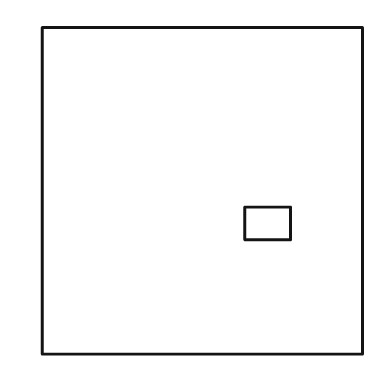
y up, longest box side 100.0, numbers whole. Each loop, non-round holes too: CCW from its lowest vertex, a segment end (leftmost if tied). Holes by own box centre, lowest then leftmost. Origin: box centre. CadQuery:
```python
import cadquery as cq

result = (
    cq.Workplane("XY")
    .moveTo(-49.0, -50.0)
    .lineTo(49.0, -50.0)
    .lineTo(49.0, 50.0)
    .lineTo(-49.0, 50.0)
    .close()
    .moveTo(13.0, -15.0)
    .lineTo(27.0, -15.0)
    .lineTo(27.0, -5.0)
    .lineTo(13.0, -5.0)
    .close()
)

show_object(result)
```